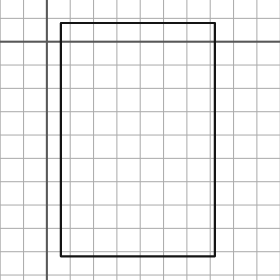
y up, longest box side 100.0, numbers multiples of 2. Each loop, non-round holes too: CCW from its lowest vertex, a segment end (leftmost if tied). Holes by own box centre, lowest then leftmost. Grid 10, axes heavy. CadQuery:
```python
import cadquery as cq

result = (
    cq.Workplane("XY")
    .moveTo(6.0, -92.0)
    .lineTo(72.0, -92.0)
    .lineTo(72.0, 8.0)
    .lineTo(6.0, 8.0)
    .close()
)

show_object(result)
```